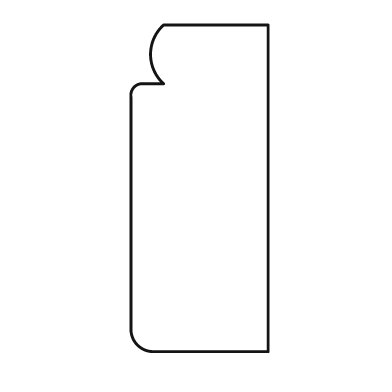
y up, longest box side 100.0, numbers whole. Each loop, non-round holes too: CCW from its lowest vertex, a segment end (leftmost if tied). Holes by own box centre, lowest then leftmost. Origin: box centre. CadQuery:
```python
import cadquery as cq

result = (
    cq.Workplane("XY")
    .moveTo(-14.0, -50.0)
    .lineTo(21.0, -50.0)
    .lineTo(21.0, 50.0)
    .lineTo(-11.0, 50.0)
    .threePointArc((-15.0, 41.0), (-11.0, 32.0))
    .lineTo(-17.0, 32.0)
    .threePointArc((-20.0, 31.0), (-21.0, 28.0))
    .lineTo(-21.0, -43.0)
    .threePointArc((-19.0, -48.0), (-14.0, -50.0))
    .close()
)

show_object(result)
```